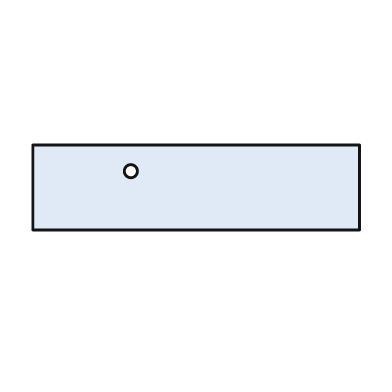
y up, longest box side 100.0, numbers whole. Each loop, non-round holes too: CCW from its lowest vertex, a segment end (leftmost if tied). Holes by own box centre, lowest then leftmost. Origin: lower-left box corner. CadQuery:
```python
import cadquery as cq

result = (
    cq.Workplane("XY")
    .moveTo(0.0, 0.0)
    .lineTo(100.0, 0.0)
    .lineTo(100.0, 26.0)
    .lineTo(0.0, 26.0)
    .close()
    .moveTo(30.0, 18.0)
    .circle(2.0)
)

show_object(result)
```